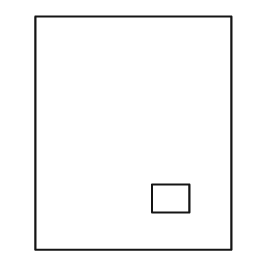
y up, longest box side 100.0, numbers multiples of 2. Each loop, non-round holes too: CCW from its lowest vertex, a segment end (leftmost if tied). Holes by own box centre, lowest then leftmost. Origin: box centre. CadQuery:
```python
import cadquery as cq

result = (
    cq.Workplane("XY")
    .moveTo(-42.0, -50.0)
    .lineTo(42.0, -50.0)
    .lineTo(42.0, 50.0)
    .lineTo(-42.0, 50.0)
    .close()
    .moveTo(8.0, -34.0)
    .lineTo(24.0, -34.0)
    .lineTo(24.0, -22.0)
    .lineTo(8.0, -22.0)
    .close()
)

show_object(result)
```